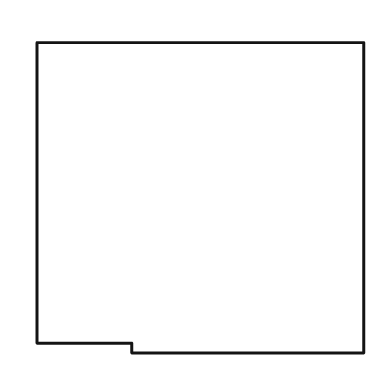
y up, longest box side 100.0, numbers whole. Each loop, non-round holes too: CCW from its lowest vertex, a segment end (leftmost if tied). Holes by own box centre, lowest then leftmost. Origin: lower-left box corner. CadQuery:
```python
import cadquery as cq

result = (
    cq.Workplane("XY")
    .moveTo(29.0, 0.0)
    .lineTo(100.0, 0.0)
    .lineTo(100.0, 95.0)
    .lineTo(0.0, 95.0)
    .lineTo(0.0, 3.0)
    .lineTo(29.0, 3.0)
    .close()
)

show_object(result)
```